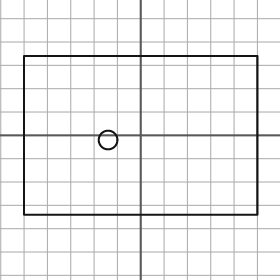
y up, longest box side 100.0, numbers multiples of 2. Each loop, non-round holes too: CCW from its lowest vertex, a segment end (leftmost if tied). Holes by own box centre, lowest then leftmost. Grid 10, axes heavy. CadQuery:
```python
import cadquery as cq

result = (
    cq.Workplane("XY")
    .moveTo(-50.0, -34.0)
    .lineTo(50.0, -34.0)
    .lineTo(50.0, 34.0)
    .lineTo(-50.0, 34.0)
    .close()
    .moveTo(-14.0, -2.0)
    .circle(4.0)
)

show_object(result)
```